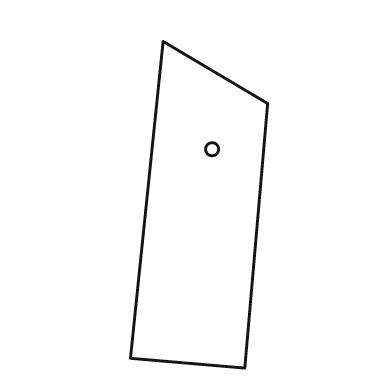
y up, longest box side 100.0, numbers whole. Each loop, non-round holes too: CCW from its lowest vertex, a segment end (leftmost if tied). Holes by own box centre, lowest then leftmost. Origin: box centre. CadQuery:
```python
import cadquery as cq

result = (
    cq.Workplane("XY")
    .moveTo(14.0, -50.0)
    .lineTo(21.0, 31.0)
    .lineTo(-11.0, 50.0)
    .lineTo(-21.0, -47.0)
    .close()
    .moveTo(4.0, 17.0)
    .circle(2.0)
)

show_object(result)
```